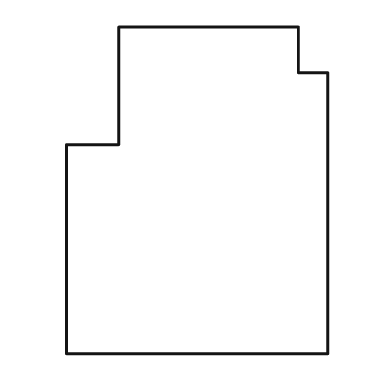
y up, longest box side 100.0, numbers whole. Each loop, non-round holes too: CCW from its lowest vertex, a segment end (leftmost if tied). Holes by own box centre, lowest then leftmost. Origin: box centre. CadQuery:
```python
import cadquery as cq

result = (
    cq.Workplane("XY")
    .moveTo(-40.0, -50.0)
    .lineTo(40.0, -50.0)
    .lineTo(40.0, 36.0)
    .lineTo(31.0, 36.0)
    .lineTo(31.0, 50.0)
    .lineTo(-24.0, 50.0)
    .lineTo(-24.0, 14.0)
    .lineTo(-40.0, 14.0)
    .close()
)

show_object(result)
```